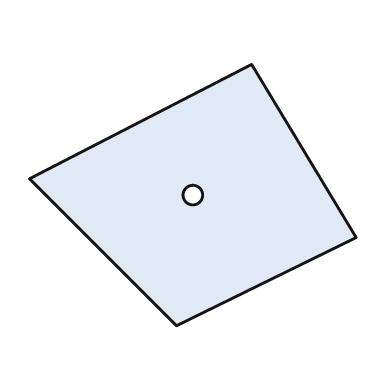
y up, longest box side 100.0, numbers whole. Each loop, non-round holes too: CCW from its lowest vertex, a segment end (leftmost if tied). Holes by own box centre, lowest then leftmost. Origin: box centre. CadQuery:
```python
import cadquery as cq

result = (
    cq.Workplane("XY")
    .moveTo(-5.0, -40.0)
    .lineTo(50.0, -13.0)
    .lineTo(18.0, 40.0)
    .lineTo(-50.0, 5.0)
    .close()
    .moveTo(0.0, 0.0)
    .circle(3.0)
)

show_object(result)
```